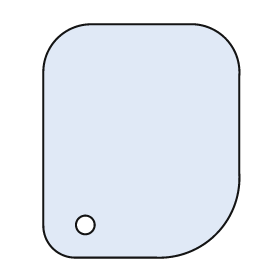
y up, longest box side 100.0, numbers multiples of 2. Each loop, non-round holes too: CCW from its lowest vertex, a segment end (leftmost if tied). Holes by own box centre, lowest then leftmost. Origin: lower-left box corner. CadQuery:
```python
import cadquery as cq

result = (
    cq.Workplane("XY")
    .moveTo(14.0, 0.0)
    .lineTo(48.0, 0.0)
    .threePointArc((74.0, 10.0), (84.0, 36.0))
    .lineTo(84.0, 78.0)
    .threePointArc((78.0, 94.0), (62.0, 100.0))
    .lineTo(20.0, 100.0)
    .threePointArc((6.0, 94.0), (0.0, 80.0))
    .lineTo(0.0, 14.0)
    .threePointArc((4.0, 4.0), (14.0, 0.0))
    .close()
    .moveTo(18.0, 14.0)
    .circle(4.0)
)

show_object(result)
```